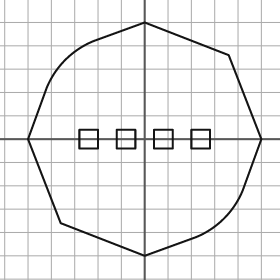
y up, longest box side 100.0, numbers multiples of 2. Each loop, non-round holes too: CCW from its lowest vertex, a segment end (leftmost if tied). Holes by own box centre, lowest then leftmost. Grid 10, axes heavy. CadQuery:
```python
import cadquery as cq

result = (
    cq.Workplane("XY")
    .moveTo(0.0, -50.0)
    .lineTo(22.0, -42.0)
    .threePointArc((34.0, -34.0), (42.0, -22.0))
    .lineTo(50.0, 0.0)
    .lineTo(36.0, 36.0)
    .lineTo(0.0, 50.0)
    .lineTo(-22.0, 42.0)
    .threePointArc((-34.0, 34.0), (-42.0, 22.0))
    .lineTo(-50.0, 0.0)
    .lineTo(-36.0, -36.0)
    .close()
    .moveTo(-28.0, -4.0)
    .lineTo(-20.0, -4.0)
    .lineTo(-20.0, 4.0)
    .lineTo(-28.0, 4.0)
    .close()
    .moveTo(-12.0, -4.0)
    .lineTo(-4.0, -4.0)
    .lineTo(-4.0, 4.0)
    .lineTo(-12.0, 4.0)
    .close()
    .moveTo(4.0, -4.0)
    .lineTo(12.0, -4.0)
    .lineTo(12.0, 4.0)
    .lineTo(4.0, 4.0)
    .close()
    .moveTo(20.0, -4.0)
    .lineTo(28.0, -4.0)
    .lineTo(28.0, 4.0)
    .lineTo(20.0, 4.0)
    .close()
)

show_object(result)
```